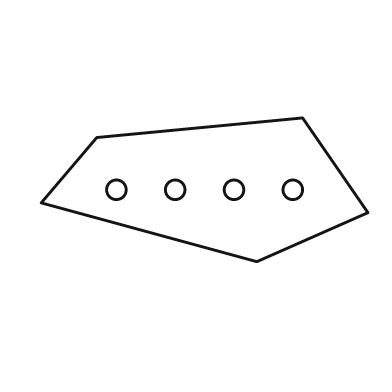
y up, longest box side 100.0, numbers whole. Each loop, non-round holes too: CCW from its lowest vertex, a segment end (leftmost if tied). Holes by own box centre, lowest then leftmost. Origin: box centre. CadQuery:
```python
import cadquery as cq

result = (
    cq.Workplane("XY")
    .moveTo(16.0, -22.0)
    .lineTo(50.0, -7.0)
    .lineTo(30.0, 22.0)
    .lineTo(-33.0, 16.0)
    .lineTo(-50.0, -4.0)
    .close()
    .moveTo(-27.0, 0.0)
    .circle(3.0)
    .moveTo(-9.0, 0.0)
    .circle(3.0)
    .moveTo(9.0, 0.0)
    .circle(3.0)
    .moveTo(27.0, 0.0)
    .circle(3.0)
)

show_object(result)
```